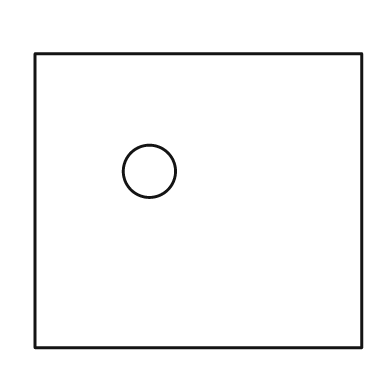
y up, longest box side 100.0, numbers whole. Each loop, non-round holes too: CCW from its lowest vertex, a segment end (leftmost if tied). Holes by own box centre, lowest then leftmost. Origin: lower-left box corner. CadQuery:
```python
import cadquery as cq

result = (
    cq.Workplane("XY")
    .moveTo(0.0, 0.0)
    .lineTo(100.0, 0.0)
    .lineTo(100.0, 90.0)
    .lineTo(0.0, 90.0)
    .close()
    .moveTo(35.0, 54.0)
    .circle(8.0)
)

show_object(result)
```